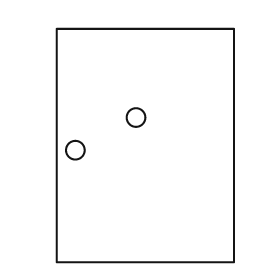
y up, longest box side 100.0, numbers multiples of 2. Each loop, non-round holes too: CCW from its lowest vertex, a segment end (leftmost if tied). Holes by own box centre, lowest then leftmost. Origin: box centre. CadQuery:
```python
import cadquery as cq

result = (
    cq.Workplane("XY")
    .moveTo(-38.0, -50.0)
    .lineTo(38.0, -50.0)
    .lineTo(38.0, 50.0)
    .lineTo(-38.0, 50.0)
    .close()
    .moveTo(-30.0, -2.0)
    .circle(4.0)
    .moveTo(-4.0, 12.0)
    .circle(4.0)
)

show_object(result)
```